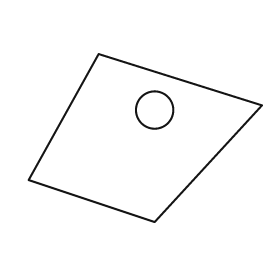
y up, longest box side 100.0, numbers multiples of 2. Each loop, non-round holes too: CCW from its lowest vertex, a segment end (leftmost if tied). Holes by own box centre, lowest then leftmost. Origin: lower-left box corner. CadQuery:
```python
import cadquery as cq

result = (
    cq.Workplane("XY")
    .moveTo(54.0, 0.0)
    .lineTo(100.0, 50.0)
    .lineTo(30.0, 72.0)
    .lineTo(0.0, 18.0)
    .close()
    .moveTo(54.0, 48.0)
    .circle(8.0)
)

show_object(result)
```